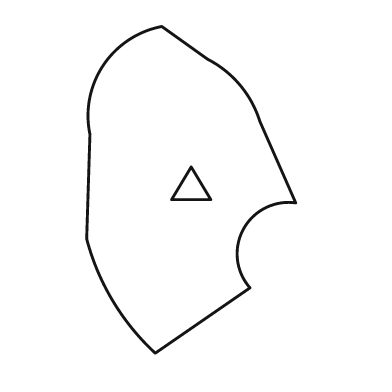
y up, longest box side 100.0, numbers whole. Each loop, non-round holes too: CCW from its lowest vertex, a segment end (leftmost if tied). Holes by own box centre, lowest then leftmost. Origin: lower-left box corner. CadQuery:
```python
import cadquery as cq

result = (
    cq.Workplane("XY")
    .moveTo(21.0, 0.0)
    .lineTo(50.0, 20.0)
    .threePointArc((48.0, 38.0), (64.0, 46.0))
    .lineTo(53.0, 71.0)
    .threePointArc((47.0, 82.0), (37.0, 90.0))
    .lineTo(23.0, 100.0)
    .threePointArc((5.0, 88.0), (1.0, 67.0))
    .lineTo(0.0, 35.0)
    .threePointArc((8.0, 16.0), (21.0, 0.0))
    .close()
    .moveTo(26.0, 47.0)
    .lineTo(38.0, 47.0)
    .lineTo(32.0, 57.0)
    .close()
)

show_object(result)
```